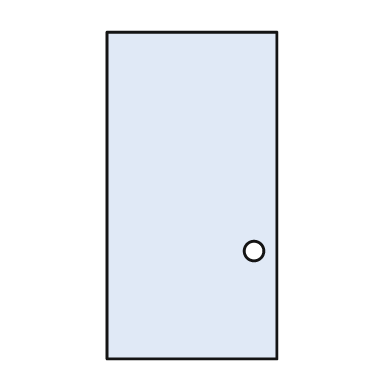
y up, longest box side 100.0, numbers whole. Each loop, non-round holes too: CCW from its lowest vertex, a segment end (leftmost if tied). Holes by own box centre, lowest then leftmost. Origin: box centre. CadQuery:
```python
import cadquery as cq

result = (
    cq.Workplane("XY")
    .moveTo(-26.0, -50.0)
    .lineTo(26.0, -50.0)
    .lineTo(26.0, 50.0)
    .lineTo(-26.0, 50.0)
    .close()
    .moveTo(19.0, -17.0)
    .circle(3.0)
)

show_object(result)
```